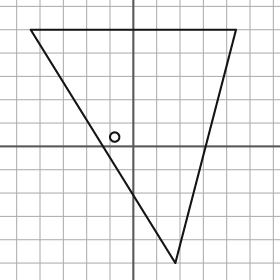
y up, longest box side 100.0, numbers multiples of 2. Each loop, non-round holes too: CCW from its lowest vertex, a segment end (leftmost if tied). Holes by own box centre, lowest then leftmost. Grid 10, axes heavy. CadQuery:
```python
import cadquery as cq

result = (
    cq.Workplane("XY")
    .moveTo(18.0, -50.0)
    .lineTo(44.0, 50.0)
    .lineTo(-44.0, 50.0)
    .close()
    .moveTo(-8.0, 4.0)
    .circle(2.0)
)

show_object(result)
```